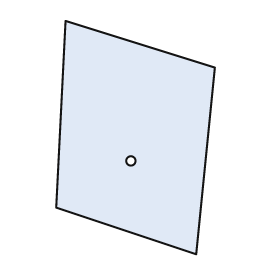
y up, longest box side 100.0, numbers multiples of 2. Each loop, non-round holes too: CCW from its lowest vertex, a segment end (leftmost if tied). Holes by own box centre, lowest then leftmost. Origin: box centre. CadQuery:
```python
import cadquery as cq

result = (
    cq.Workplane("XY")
    .moveTo(26.0, -50.0)
    .lineTo(34.0, 30.0)
    .lineTo(-30.0, 50.0)
    .lineTo(-34.0, -30.0)
    .close()
    .moveTo(-2.0, -10.0)
    .circle(2.0)
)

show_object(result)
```